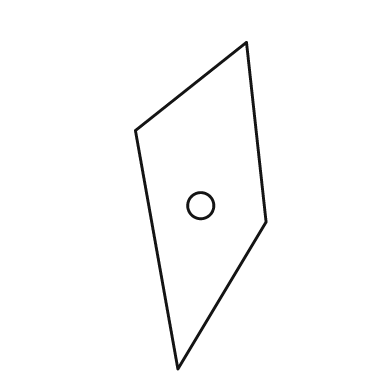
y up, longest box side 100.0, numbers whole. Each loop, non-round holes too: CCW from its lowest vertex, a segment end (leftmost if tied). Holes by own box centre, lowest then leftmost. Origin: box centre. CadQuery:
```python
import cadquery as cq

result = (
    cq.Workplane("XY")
    .moveTo(-7.0, -50.0)
    .lineTo(20.0, -5.0)
    .lineTo(14.0, 50.0)
    .lineTo(-20.0, 23.0)
    .close()
    .moveTo(0.0, 0.0)
    .circle(4.0)
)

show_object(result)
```